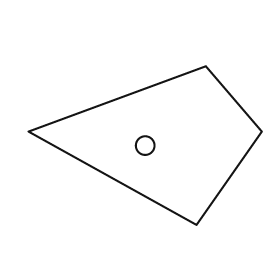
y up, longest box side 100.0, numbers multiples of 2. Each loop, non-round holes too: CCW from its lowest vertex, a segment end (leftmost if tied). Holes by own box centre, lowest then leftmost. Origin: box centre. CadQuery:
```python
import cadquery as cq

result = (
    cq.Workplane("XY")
    .moveTo(22.0, -34.0)
    .lineTo(50.0, 6.0)
    .lineTo(26.0, 34.0)
    .lineTo(-50.0, 6.0)
    .close()
    .moveTo(0.0, 0.0)
    .circle(4.0)
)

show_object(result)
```